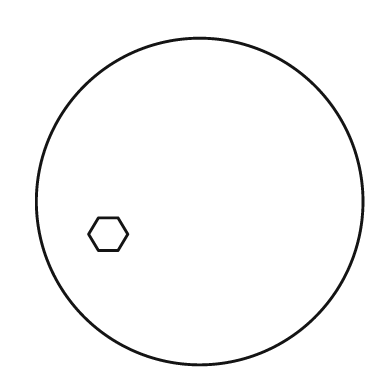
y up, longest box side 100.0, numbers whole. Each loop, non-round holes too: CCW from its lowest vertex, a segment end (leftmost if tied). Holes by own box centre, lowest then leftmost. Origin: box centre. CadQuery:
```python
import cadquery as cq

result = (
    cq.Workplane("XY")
    .moveTo(0.0, 0.0)
    .circle(50.0)
    .moveTo(-31.0, -15.0)
    .lineTo(-25.0, -15.0)
    .lineTo(-22.0, -10.0)
    .lineTo(-25.0, -5.0)
    .lineTo(-31.0, -5.0)
    .lineTo(-34.0, -10.0)
    .close()
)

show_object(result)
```